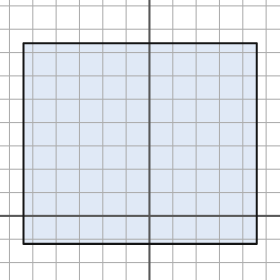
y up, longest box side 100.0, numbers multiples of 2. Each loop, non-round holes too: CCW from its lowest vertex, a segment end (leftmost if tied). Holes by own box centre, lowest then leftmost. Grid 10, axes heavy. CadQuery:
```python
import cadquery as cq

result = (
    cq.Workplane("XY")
    .moveTo(-54.0, -12.0)
    .lineTo(46.0, -12.0)
    .lineTo(46.0, 74.0)
    .lineTo(-54.0, 74.0)
    .close()
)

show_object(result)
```